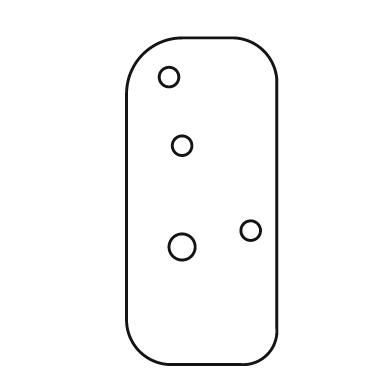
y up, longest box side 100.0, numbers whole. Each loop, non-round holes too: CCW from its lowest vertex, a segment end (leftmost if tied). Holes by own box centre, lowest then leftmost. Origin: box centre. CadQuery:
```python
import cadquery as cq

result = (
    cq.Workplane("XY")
    .moveTo(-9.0, -50.0)
    .lineTo(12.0, -50.0)
    .threePointArc((20.0, -47.0), (23.0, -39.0))
    .lineTo(23.0, 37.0)
    .threePointArc((19.0, 46.0), (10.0, 50.0))
    .lineTo(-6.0, 50.0)
    .threePointArc((-18.0, 45.0), (-23.0, 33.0))
    .lineTo(-23.0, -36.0)
    .threePointArc((-19.0, -46.0), (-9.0, -50.0))
    .close()
    .moveTo(-6.0, -14.0)
    .circle(4.0)
    .moveTo(15.0, -9.0)
    .circle(3.0)
    .moveTo(-6.0, 17.0)
    .circle(3.0)
    .moveTo(-10.0, 38.0)
    .circle(3.0)
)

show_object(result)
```